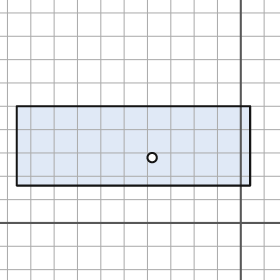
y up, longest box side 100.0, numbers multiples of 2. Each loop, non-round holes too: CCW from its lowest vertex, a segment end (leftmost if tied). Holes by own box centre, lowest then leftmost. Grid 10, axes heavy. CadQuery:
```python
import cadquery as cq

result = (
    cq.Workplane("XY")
    .moveTo(-96.0, 16.0)
    .lineTo(4.0, 16.0)
    .lineTo(4.0, 50.0)
    .lineTo(-96.0, 50.0)
    .close()
    .moveTo(-38.0, 28.0)
    .circle(2.0)
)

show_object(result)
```